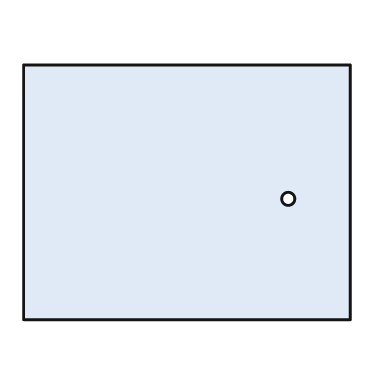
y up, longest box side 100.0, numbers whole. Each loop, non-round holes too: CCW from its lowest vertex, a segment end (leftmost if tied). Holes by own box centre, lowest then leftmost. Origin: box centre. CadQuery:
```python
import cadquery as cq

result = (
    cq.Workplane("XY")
    .moveTo(-50.0, -39.0)
    .lineTo(50.0, -39.0)
    .lineTo(50.0, 39.0)
    .lineTo(-50.0, 39.0)
    .close()
    .moveTo(31.0, -2.0)
    .circle(2.0)
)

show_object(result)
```